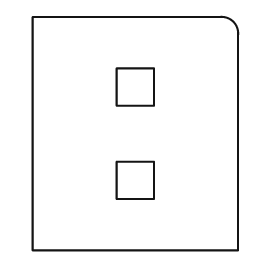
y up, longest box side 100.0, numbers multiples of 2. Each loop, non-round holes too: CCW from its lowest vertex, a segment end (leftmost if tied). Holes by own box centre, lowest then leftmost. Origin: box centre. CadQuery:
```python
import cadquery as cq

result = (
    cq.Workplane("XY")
    .moveTo(-44.0, -50.0)
    .lineTo(44.0, -50.0)
    .lineTo(44.0, 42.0)
    .threePointArc((42.0, 48.0), (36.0, 50.0))
    .lineTo(-44.0, 50.0)
    .close()
    .moveTo(-8.0, -28.0)
    .lineTo(8.0, -28.0)
    .lineTo(8.0, -12.0)
    .lineTo(-8.0, -12.0)
    .close()
    .moveTo(-8.0, 12.0)
    .lineTo(8.0, 12.0)
    .lineTo(8.0, 28.0)
    .lineTo(-8.0, 28.0)
    .close()
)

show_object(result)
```